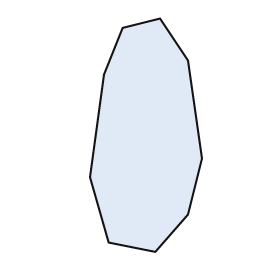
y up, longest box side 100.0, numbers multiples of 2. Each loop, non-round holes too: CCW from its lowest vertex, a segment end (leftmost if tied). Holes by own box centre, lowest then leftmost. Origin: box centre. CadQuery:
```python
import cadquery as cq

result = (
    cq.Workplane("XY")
    .moveTo(4.0, -50.0)
    .lineTo(18.0, -34.0)
    .lineTo(24.0, -10.0)
    .lineTo(18.0, 32.0)
    .lineTo(6.0, 50.0)
    .lineTo(-10.0, 46.0)
    .lineTo(-18.0, 26.0)
    .lineTo(-24.0, -18.0)
    .lineTo(-16.0, -46.0)
    .close()
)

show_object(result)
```